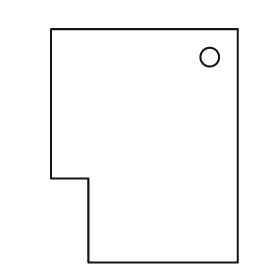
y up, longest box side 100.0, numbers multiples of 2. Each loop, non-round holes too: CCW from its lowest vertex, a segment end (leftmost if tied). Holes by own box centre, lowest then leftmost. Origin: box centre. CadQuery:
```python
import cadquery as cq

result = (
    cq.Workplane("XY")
    .moveTo(-24.0, -50.0)
    .lineTo(40.0, -50.0)
    .lineTo(40.0, 50.0)
    .lineTo(-40.0, 50.0)
    .lineTo(-40.0, -14.0)
    .lineTo(-24.0, -14.0)
    .close()
    .moveTo(28.0, 38.0)
    .circle(4.0)
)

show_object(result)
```